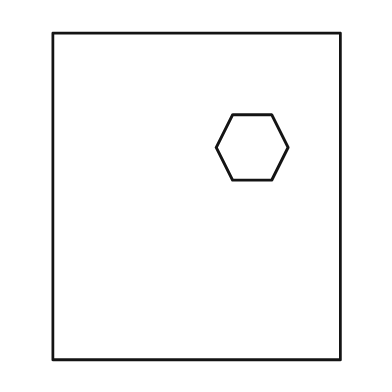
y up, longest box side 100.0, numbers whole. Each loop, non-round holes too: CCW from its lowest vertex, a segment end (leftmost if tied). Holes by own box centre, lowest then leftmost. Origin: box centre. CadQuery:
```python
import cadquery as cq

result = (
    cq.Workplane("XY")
    .moveTo(-44.0, -50.0)
    .lineTo(44.0, -50.0)
    .lineTo(44.0, 50.0)
    .lineTo(-44.0, 50.0)
    .close()
    .moveTo(11.0, 5.0)
    .lineTo(23.0, 5.0)
    .lineTo(28.0, 15.0)
    .lineTo(23.0, 25.0)
    .lineTo(11.0, 25.0)
    .lineTo(6.0, 15.0)
    .close()
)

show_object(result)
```